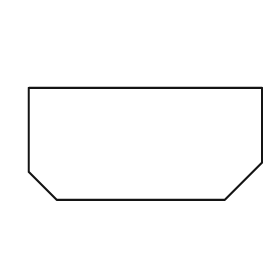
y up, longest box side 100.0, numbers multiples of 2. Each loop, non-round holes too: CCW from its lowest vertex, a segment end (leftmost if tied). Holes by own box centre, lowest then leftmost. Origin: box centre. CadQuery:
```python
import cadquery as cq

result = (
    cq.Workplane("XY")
    .moveTo(-38.0, -24.0)
    .lineTo(34.0, -24.0)
    .lineTo(50.0, -8.0)
    .lineTo(50.0, 24.0)
    .lineTo(-50.0, 24.0)
    .lineTo(-50.0, -12.0)
    .close()
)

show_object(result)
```